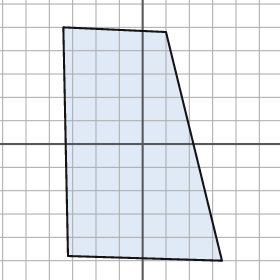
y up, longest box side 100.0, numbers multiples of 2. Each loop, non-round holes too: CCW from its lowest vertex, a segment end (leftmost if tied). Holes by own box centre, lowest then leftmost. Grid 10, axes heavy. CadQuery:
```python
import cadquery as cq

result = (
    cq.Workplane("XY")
    .moveTo(34.0, -50.0)
    .lineTo(10.0, 48.0)
    .lineTo(-34.0, 50.0)
    .lineTo(-32.0, -48.0)
    .close()
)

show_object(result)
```